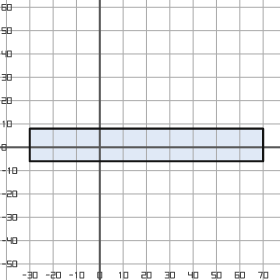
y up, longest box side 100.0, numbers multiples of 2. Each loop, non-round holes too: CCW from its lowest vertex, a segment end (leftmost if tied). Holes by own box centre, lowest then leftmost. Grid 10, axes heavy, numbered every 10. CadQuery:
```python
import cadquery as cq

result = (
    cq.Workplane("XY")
    .moveTo(-30.0, -6.0)
    .lineTo(70.0, -6.0)
    .lineTo(70.0, 8.0)
    .lineTo(-30.0, 8.0)
    .close()
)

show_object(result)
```